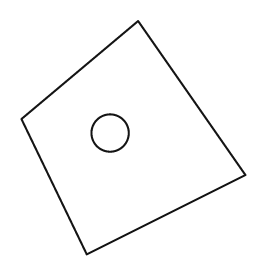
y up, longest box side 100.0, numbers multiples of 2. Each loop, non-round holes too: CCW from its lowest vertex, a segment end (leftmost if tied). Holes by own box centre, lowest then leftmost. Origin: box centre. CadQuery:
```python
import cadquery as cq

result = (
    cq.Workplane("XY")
    .moveTo(-20.0, -50.0)
    .lineTo(48.0, -16.0)
    .lineTo(2.0, 50.0)
    .lineTo(-48.0, 8.0)
    .close()
    .moveTo(-10.0, 2.0)
    .circle(8.0)
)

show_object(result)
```